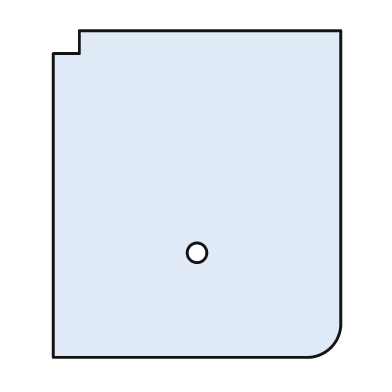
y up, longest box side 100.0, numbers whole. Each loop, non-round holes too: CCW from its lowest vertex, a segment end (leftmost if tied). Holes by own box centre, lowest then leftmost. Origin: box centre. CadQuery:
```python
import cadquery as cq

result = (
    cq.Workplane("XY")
    .moveTo(-44.0, -50.0)
    .lineTo(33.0, -50.0)
    .threePointArc((41.0, -47.0), (44.0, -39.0))
    .lineTo(44.0, 50.0)
    .lineTo(-36.0, 50.0)
    .lineTo(-36.0, 43.0)
    .lineTo(-44.0, 43.0)
    .close()
    .moveTo(0.0, -18.0)
    .circle(3.0)
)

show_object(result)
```